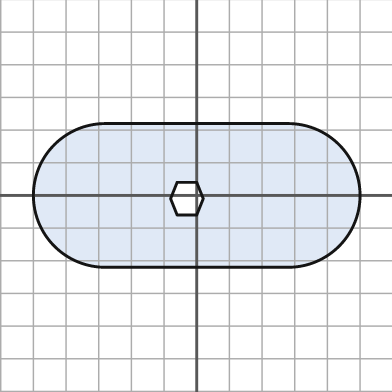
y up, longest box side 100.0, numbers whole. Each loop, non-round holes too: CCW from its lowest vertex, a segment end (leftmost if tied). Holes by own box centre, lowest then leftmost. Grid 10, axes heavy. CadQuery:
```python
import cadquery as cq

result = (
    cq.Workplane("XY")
    .moveTo(-28.0, -22.0)
    .lineTo(28.0, -22.0)
    .threePointArc((50.0, 0.0), (28.0, 22.0))
    .lineTo(-28.0, 22.0)
    .threePointArc((-50.0, 0.0), (-28.0, -22.0))
    .close()
    .moveTo(-6.0, -6.0)
    .lineTo(0.0, -6.0)
    .lineTo(2.0, -1.0)
    .lineTo(0.0, 4.0)
    .lineTo(-6.0, 4.0)
    .lineTo(-8.0, -1.0)
    .close()
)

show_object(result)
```